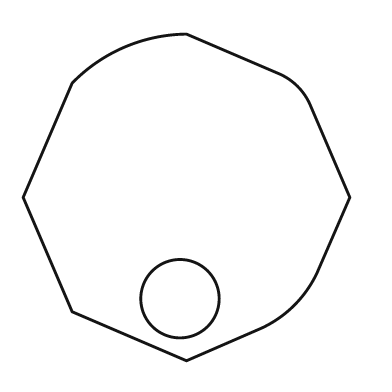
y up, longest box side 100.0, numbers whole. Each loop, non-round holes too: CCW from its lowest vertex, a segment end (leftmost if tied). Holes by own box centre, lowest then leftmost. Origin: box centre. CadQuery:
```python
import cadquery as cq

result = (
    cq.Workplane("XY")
    .moveTo(0.0, -50.0)
    .lineTo(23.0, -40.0)
    .threePointArc((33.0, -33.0), (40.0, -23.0))
    .lineTo(50.0, 0.0)
    .lineTo(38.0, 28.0)
    .threePointArc((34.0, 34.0), (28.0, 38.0))
    .lineTo(0.0, 50.0)
    .threePointArc((-19.0, 46.0), (-35.0, 35.0))
    .lineTo(-50.0, 0.0)
    .lineTo(-35.0, -35.0)
    .close()
    .moveTo(-2.0, -31.0)
    .circle(12.0)
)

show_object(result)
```